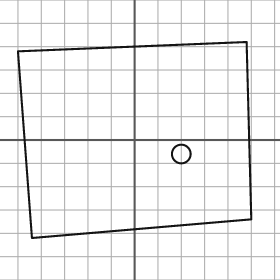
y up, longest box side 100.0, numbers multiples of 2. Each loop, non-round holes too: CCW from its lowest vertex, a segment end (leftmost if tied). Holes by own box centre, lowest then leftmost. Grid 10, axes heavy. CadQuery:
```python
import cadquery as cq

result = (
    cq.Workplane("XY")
    .moveTo(-44.0, -42.0)
    .lineTo(50.0, -34.0)
    .lineTo(48.0, 42.0)
    .lineTo(-50.0, 38.0)
    .close()
    .moveTo(20.0, -6.0)
    .circle(4.0)
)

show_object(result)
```